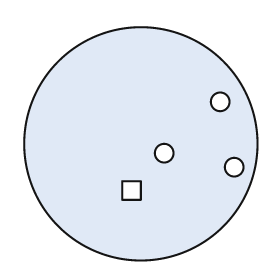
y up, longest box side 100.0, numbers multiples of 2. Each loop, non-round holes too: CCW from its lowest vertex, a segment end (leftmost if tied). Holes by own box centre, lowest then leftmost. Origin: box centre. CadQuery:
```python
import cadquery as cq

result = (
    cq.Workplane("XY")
    .moveTo(0.0, 0.0)
    .circle(50.0)
    .moveTo(-8.0, -24.0)
    .lineTo(0.0, -24.0)
    .lineTo(0.0, -16.0)
    .lineTo(-8.0, -16.0)
    .close()
    .moveTo(40.0, -10.0)
    .circle(4.0)
    .moveTo(10.0, -4.0)
    .circle(4.0)
    .moveTo(34.0, 18.0)
    .circle(4.0)
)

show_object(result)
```